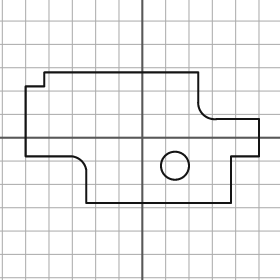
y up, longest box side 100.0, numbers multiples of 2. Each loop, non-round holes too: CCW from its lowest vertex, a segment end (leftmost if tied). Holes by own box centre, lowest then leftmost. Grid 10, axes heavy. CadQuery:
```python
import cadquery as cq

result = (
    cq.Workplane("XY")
    .moveTo(-24.0, -28.0)
    .lineTo(38.0, -28.0)
    .lineTo(38.0, -8.0)
    .lineTo(50.0, -8.0)
    .lineTo(50.0, 8.0)
    .lineTo(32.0, 8.0)
    .threePointArc((26.0, 10.0), (24.0, 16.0))
    .lineTo(24.0, 28.0)
    .lineTo(-42.0, 28.0)
    .lineTo(-42.0, 22.0)
    .lineTo(-50.0, 22.0)
    .lineTo(-50.0, -8.0)
    .lineTo(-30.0, -8.0)
    .threePointArc((-26.0, -10.0), (-24.0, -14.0))
    .close()
    .moveTo(14.0, -12.0)
    .circle(6.0)
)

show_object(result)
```